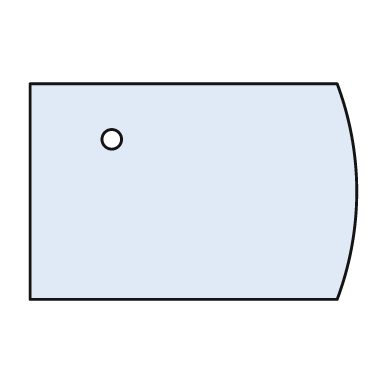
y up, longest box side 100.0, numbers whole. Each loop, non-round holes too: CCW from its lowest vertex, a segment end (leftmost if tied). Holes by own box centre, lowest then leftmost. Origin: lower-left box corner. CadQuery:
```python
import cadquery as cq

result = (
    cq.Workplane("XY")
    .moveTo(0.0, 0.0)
    .lineTo(94.0, 0.0)
    .threePointArc((100.0, 33.0), (94.0, 66.0))
    .lineTo(0.0, 66.0)
    .close()
    .moveTo(25.0, 49.0)
    .circle(3.0)
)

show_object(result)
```